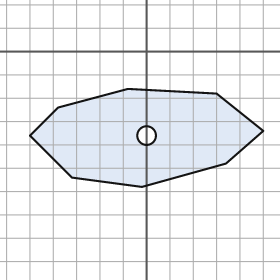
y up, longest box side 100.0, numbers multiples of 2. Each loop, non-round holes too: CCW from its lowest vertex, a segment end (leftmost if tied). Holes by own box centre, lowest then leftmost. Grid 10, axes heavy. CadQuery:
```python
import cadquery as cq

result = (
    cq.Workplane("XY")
    .moveTo(-2.0, -58.0)
    .lineTo(34.0, -48.0)
    .lineTo(50.0, -34.0)
    .lineTo(30.0, -18.0)
    .lineTo(-8.0, -16.0)
    .lineTo(-38.0, -24.0)
    .lineTo(-50.0, -36.0)
    .lineTo(-32.0, -54.0)
    .close()
    .moveTo(0.0, -36.0)
    .circle(4.0)
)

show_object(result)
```